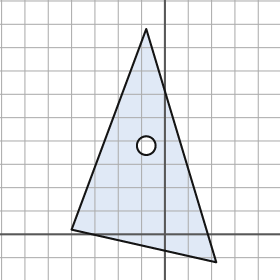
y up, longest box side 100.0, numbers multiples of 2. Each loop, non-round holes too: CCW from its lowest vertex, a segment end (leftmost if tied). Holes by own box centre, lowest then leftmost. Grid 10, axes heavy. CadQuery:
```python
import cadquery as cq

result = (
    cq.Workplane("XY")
    .moveTo(22.0, -12.0)
    .lineTo(-8.0, 88.0)
    .lineTo(-40.0, 2.0)
    .close()
    .moveTo(-8.0, 38.0)
    .circle(4.0)
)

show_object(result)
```